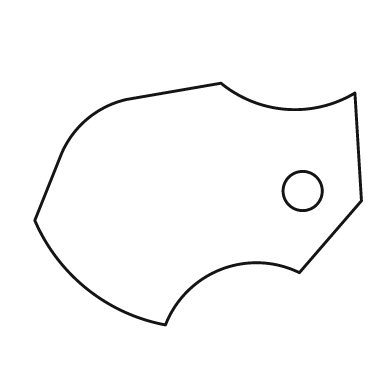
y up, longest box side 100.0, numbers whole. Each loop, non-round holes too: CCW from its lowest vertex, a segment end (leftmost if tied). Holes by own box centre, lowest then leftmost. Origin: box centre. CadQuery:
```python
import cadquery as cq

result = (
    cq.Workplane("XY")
    .moveTo(-10.0, -37.0)
    .threePointArc((7.0, -20.0), (31.0, -21.0))
    .lineTo(50.0, 1.0)
    .lineTo(48.0, 34.0)
    .threePointArc((27.0, 29.0), (7.0, 37.0))
    .lineTo(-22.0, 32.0)
    .threePointArc((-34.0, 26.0), (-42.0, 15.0))
    .lineTo(-50.0, -5.0)
    .threePointArc((-34.0, -26.0), (-10.0, -37.0))
    .close()
    .moveTo(32.0, 4.0)
    .circle(6.0)
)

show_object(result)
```